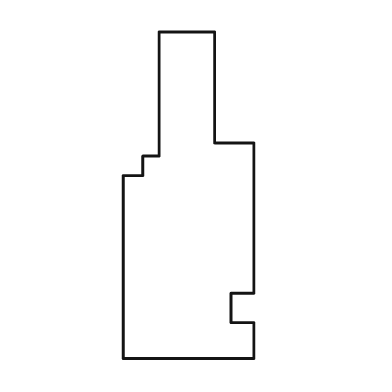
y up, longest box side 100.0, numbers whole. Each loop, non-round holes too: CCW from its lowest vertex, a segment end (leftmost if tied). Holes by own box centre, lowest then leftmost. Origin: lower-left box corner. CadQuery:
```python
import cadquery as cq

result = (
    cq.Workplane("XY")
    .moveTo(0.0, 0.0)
    .lineTo(40.0, 0.0)
    .lineTo(40.0, 11.0)
    .lineTo(33.0, 11.0)
    .lineTo(33.0, 20.0)
    .lineTo(40.0, 20.0)
    .lineTo(40.0, 66.0)
    .lineTo(28.0, 66.0)
    .lineTo(28.0, 100.0)
    .lineTo(11.0, 100.0)
    .lineTo(11.0, 62.0)
    .lineTo(6.0, 62.0)
    .lineTo(6.0, 56.0)
    .lineTo(0.0, 56.0)
    .close()
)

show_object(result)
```